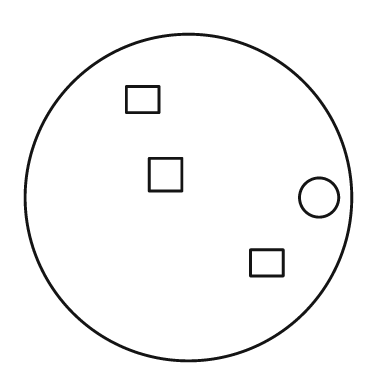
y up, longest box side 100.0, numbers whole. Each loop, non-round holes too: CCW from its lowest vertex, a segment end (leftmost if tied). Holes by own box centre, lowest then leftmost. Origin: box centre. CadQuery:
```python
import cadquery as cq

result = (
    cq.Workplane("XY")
    .moveTo(0.0, 0.0)
    .circle(50.0)
    .moveTo(19.0, -24.0)
    .lineTo(29.0, -24.0)
    .lineTo(29.0, -16.0)
    .lineTo(19.0, -16.0)
    .close()
    .moveTo(40.0, 0.0)
    .circle(6.0)
    .moveTo(-12.0, 2.0)
    .lineTo(-2.0, 2.0)
    .lineTo(-2.0, 12.0)
    .lineTo(-12.0, 12.0)
    .close()
    .moveTo(-19.0, 26.0)
    .lineTo(-9.0, 26.0)
    .lineTo(-9.0, 34.0)
    .lineTo(-19.0, 34.0)
    .close()
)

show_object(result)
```